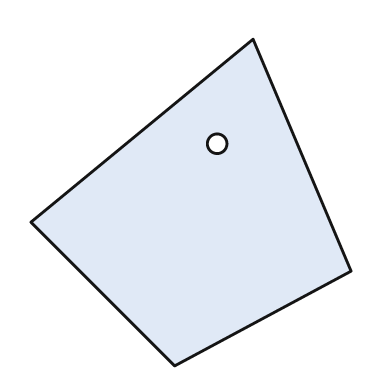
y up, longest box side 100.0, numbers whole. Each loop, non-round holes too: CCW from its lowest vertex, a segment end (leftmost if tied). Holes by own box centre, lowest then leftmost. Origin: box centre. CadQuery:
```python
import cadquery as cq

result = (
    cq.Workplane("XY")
    .moveTo(-5.0, -50.0)
    .lineTo(49.0, -21.0)
    .lineTo(19.0, 50.0)
    .lineTo(-49.0, -6.0)
    .close()
    .moveTo(8.0, 18.0)
    .circle(3.0)
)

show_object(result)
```